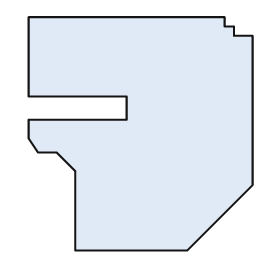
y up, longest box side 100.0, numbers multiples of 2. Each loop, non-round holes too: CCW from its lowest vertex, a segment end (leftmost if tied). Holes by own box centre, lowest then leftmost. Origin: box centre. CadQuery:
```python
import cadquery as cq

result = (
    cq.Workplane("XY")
    .moveTo(-28.0, -50.0)
    .lineTo(20.0, -50.0)
    .lineTo(48.0, -22.0)
    .lineTo(48.0, 42.0)
    .lineTo(40.0, 42.0)
    .lineTo(40.0, 46.0)
    .lineTo(36.0, 46.0)
    .lineTo(36.0, 50.0)
    .lineTo(-48.0, 50.0)
    .lineTo(-48.0, 16.0)
    .lineTo(-6.0, 16.0)
    .lineTo(-6.0, 6.0)
    .lineTo(-48.0, 6.0)
    .lineTo(-48.0, -2.0)
    .lineTo(-44.0, -8.0)
    .lineTo(-36.0, -8.0)
    .lineTo(-28.0, -16.0)
    .close()
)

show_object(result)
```